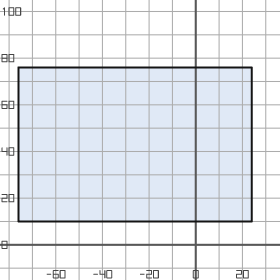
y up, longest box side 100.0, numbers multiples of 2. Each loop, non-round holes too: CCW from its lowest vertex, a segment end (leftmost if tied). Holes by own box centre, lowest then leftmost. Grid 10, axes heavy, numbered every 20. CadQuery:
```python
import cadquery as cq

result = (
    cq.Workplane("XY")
    .moveTo(-76.0, 10.0)
    .lineTo(24.0, 10.0)
    .lineTo(24.0, 76.0)
    .lineTo(-76.0, 76.0)
    .close()
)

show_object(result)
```